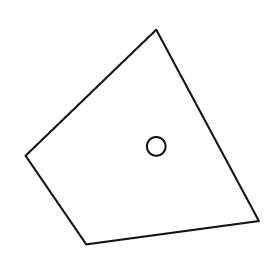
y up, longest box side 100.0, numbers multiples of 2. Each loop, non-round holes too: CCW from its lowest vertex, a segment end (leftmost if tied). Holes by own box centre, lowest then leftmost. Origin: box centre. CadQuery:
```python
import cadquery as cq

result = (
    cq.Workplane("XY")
    .moveTo(-24.0, -46.0)
    .lineTo(50.0, -36.0)
    .lineTo(6.0, 46.0)
    .lineTo(-50.0, -8.0)
    .close()
    .moveTo(6.0, -4.0)
    .circle(4.0)
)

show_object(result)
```